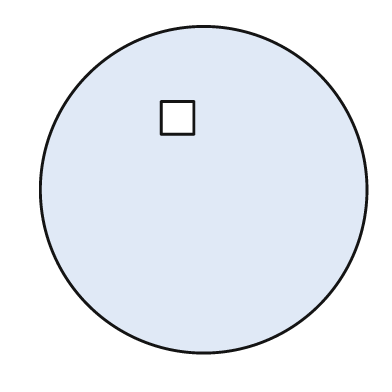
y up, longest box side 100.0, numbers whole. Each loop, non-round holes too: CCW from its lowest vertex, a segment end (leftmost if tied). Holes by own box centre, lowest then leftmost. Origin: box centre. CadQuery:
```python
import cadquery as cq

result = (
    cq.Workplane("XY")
    .moveTo(0.0, 0.0)
    .circle(50.0)
    .moveTo(-13.0, 17.0)
    .lineTo(-3.0, 17.0)
    .lineTo(-3.0, 27.0)
    .lineTo(-13.0, 27.0)
    .close()
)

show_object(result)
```